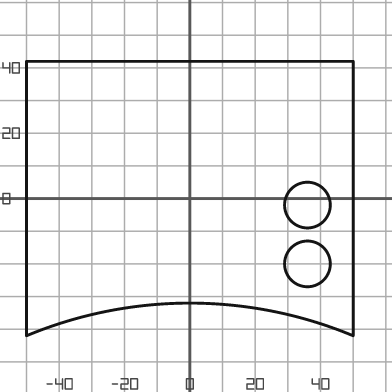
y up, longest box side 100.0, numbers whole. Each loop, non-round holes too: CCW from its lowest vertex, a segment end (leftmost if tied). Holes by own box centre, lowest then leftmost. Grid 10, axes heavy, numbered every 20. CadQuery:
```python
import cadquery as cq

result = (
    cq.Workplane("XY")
    .moveTo(-50.0, -42.0)
    .threePointArc((0.0, -32.0), (50.0, -42.0))
    .lineTo(50.0, 42.0)
    .lineTo(-50.0, 42.0)
    .close()
    .moveTo(36.0, -20.0)
    .circle(7.0)
    .moveTo(36.0, -2.0)
    .circle(7.0)
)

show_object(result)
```